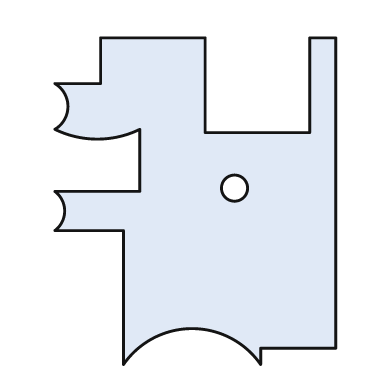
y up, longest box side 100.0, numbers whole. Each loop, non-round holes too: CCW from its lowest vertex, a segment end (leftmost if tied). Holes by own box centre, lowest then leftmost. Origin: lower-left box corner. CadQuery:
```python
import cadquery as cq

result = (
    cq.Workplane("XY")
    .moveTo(21.0, 0.0)
    .threePointArc((42.0, 11.0), (63.0, 0.0))
    .lineTo(63.0, 5.0)
    .lineTo(86.0, 5.0)
    .lineTo(86.0, 100.0)
    .lineTo(78.0, 100.0)
    .lineTo(78.0, 71.0)
    .lineTo(46.0, 71.0)
    .lineTo(46.0, 100.0)
    .lineTo(14.0, 100.0)
    .lineTo(14.0, 86.0)
    .lineTo(0.0, 86.0)
    .threePointArc((4.0, 79.0), (0.0, 72.0))
    .threePointArc((13.0, 69.0), (26.0, 72.0))
    .lineTo(26.0, 53.0)
    .lineTo(0.0, 53.0)
    .threePointArc((3.0, 47.0), (0.0, 41.0))
    .lineTo(21.0, 41.0)
    .close()
    .moveTo(55.0, 54.0)
    .circle(4.0)
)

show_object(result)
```